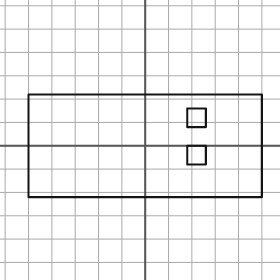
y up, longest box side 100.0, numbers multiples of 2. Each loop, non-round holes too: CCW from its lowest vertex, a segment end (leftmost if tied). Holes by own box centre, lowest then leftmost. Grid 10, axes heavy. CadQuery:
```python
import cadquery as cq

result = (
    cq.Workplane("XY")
    .moveTo(-50.0, -22.0)
    .lineTo(50.0, -22.0)
    .lineTo(50.0, 22.0)
    .lineTo(-50.0, 22.0)
    .close()
    .moveTo(18.0, -8.0)
    .lineTo(26.0, -8.0)
    .lineTo(26.0, 0.0)
    .lineTo(18.0, 0.0)
    .close()
    .moveTo(18.0, 8.0)
    .lineTo(26.0, 8.0)
    .lineTo(26.0, 16.0)
    .lineTo(18.0, 16.0)
    .close()
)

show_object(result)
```